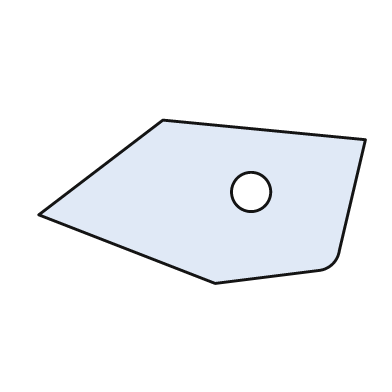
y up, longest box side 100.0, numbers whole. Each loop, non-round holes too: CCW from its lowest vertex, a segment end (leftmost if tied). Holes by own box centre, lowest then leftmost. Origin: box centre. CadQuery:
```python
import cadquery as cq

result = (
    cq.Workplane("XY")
    .moveTo(4.0, -25.0)
    .lineTo(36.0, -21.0)
    .threePointArc((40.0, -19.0), (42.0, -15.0))
    .lineTo(50.0, 19.0)
    .lineTo(-12.0, 25.0)
    .lineTo(-50.0, -4.0)
    .close()
    .moveTo(15.0, 3.0)
    .circle(6.0)
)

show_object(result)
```